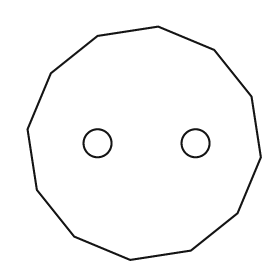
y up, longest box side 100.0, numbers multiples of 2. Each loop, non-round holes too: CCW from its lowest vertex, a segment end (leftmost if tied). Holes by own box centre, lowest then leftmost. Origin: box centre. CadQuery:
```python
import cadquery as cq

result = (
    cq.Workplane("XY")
    .moveTo(-6.0, -50.0)
    .lineTo(20.0, -46.0)
    .lineTo(40.0, -30.0)
    .lineTo(50.0, -6.0)
    .lineTo(46.0, 20.0)
    .lineTo(30.0, 40.0)
    .lineTo(6.0, 50.0)
    .lineTo(-20.0, 46.0)
    .lineTo(-40.0, 30.0)
    .lineTo(-50.0, 6.0)
    .lineTo(-46.0, -20.0)
    .lineTo(-30.0, -40.0)
    .close()
    .moveTo(-20.0, 0.0)
    .circle(6.0)
    .moveTo(22.0, 0.0)
    .circle(6.0)
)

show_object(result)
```